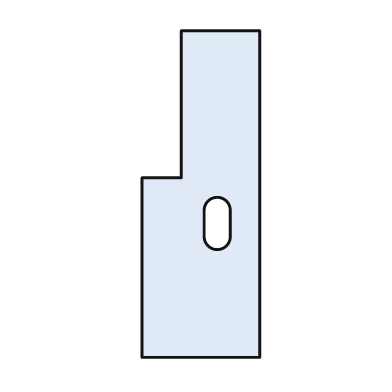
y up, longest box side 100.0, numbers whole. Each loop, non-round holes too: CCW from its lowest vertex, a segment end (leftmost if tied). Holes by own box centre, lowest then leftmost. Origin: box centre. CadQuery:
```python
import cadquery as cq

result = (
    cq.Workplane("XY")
    .moveTo(-18.0, -50.0)
    .lineTo(18.0, -50.0)
    .lineTo(18.0, 50.0)
    .lineTo(-6.0, 50.0)
    .lineTo(-6.0, 5.0)
    .lineTo(-18.0, 5.0)
    .close()
    .moveTo(1.0, -13.0)
    .threePointArc((5.0, -17.0), (9.0, -13.0))
    .lineTo(9.0, -5.0)
    .threePointArc((5.0, -1.0), (1.0, -5.0))
    .close()
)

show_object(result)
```